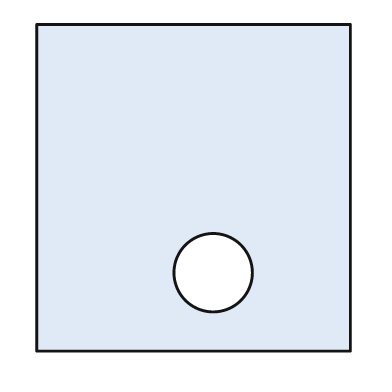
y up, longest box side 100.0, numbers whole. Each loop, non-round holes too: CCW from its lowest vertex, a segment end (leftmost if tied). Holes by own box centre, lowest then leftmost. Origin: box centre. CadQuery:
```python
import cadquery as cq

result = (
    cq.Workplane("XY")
    .moveTo(-48.0, -50.0)
    .lineTo(48.0, -50.0)
    .lineTo(48.0, 50.0)
    .lineTo(-48.0, 50.0)
    .close()
    .moveTo(6.0, -26.0)
    .circle(12.0)
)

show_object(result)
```